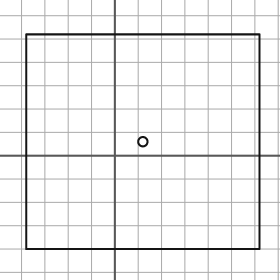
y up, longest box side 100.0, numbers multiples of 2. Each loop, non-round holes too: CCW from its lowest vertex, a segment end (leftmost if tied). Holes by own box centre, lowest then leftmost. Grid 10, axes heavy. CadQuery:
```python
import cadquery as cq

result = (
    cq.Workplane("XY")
    .moveTo(-38.0, -40.0)
    .lineTo(62.0, -40.0)
    .lineTo(62.0, 52.0)
    .lineTo(-38.0, 52.0)
    .close()
    .moveTo(12.0, 6.0)
    .circle(2.0)
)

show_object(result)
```